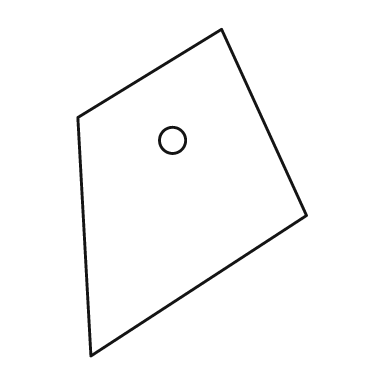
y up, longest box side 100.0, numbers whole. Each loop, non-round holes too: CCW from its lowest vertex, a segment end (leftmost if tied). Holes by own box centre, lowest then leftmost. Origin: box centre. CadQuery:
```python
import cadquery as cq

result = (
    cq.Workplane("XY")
    .moveTo(-31.0, -50.0)
    .lineTo(35.0, -7.0)
    .lineTo(9.0, 50.0)
    .lineTo(-35.0, 23.0)
    .close()
    .moveTo(-6.0, 16.0)
    .circle(4.0)
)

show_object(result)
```